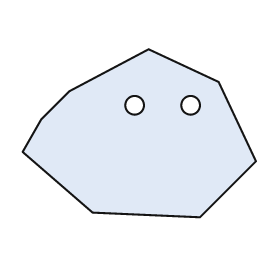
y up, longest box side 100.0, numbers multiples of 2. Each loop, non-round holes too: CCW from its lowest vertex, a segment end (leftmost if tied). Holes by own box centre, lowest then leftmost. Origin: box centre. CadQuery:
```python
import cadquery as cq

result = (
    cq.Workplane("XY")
    .moveTo(26.0, -36.0)
    .lineTo(50.0, -12.0)
    .lineTo(34.0, 22.0)
    .lineTo(4.0, 36.0)
    .lineTo(-30.0, 18.0)
    .lineTo(-42.0, 6.0)
    .lineTo(-50.0, -8.0)
    .lineTo(-20.0, -34.0)
    .close()
    .moveTo(-2.0, 12.0)
    .circle(4.0)
    .moveTo(22.0, 12.0)
    .circle(4.0)
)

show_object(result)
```